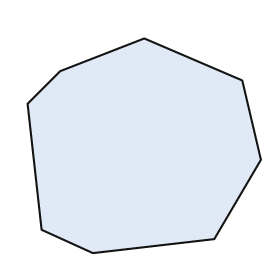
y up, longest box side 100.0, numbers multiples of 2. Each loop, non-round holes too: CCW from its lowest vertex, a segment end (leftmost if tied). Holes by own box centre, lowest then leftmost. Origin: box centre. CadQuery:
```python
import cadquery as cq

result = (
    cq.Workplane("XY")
    .moveTo(-22.0, -46.0)
    .lineTo(30.0, -40.0)
    .lineTo(50.0, -6.0)
    .lineTo(42.0, 28.0)
    .lineTo(0.0, 46.0)
    .lineTo(-36.0, 32.0)
    .lineTo(-50.0, 18.0)
    .lineTo(-44.0, -36.0)
    .close()
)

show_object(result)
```